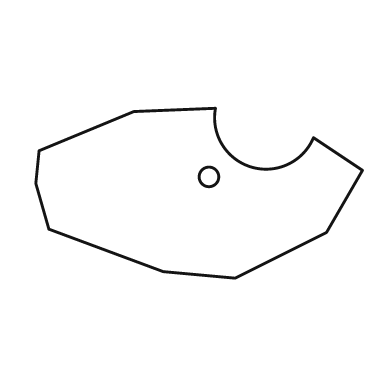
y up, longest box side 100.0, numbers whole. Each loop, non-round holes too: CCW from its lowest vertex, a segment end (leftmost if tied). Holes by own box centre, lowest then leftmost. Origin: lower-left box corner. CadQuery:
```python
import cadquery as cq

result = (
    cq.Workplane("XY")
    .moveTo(61.0, 0.0)
    .lineTo(89.0, 14.0)
    .lineTo(100.0, 33.0)
    .lineTo(85.0, 43.0)
    .threePointArc((66.0, 34.0), (55.0, 52.0))
    .lineTo(30.0, 51.0)
    .lineTo(1.0, 39.0)
    .lineTo(0.0, 29.0)
    .lineTo(4.0, 15.0)
    .lineTo(39.0, 2.0)
    .close()
    .moveTo(53.0, 31.0)
    .circle(3.0)
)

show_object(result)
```